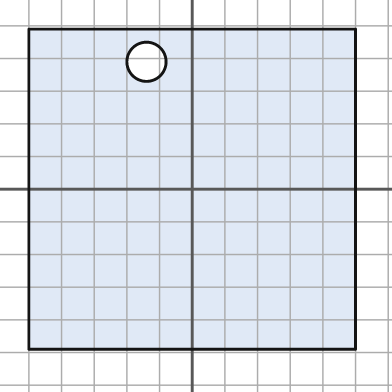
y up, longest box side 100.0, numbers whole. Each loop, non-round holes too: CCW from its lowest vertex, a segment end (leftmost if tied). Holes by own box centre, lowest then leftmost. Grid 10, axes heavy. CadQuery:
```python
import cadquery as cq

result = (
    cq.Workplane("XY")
    .moveTo(-50.0, -49.0)
    .lineTo(50.0, -49.0)
    .lineTo(50.0, 49.0)
    .lineTo(-50.0, 49.0)
    .close()
    .moveTo(-14.0, 39.0)
    .circle(6.0)
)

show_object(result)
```